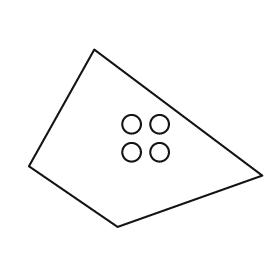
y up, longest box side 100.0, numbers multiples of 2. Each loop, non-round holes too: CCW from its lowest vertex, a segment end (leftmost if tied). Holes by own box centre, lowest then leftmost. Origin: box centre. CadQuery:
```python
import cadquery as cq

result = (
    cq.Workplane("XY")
    .moveTo(-12.0, -38.0)
    .lineTo(50.0, -16.0)
    .lineTo(-22.0, 38.0)
    .lineTo(-50.0, -12.0)
    .close()
    .moveTo(-6.0, -6.0)
    .circle(4.0)
    .moveTo(6.0, -6.0)
    .circle(4.0)
    .moveTo(-6.0, 6.0)
    .circle(4.0)
    .moveTo(6.0, 6.0)
    .circle(4.0)
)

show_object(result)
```